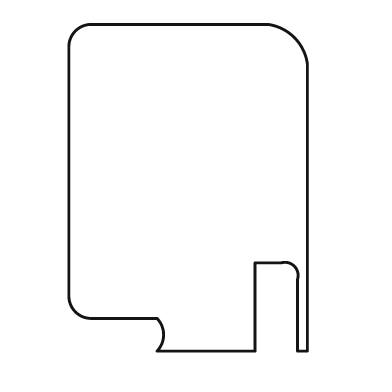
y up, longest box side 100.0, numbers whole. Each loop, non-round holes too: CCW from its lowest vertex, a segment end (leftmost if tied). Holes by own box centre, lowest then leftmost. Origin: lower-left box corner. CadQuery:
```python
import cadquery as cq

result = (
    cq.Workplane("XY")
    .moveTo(27.0, 0.0)
    .lineTo(57.0, 0.0)
    .lineTo(57.0, 27.0)
    .lineTo(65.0, 27.0)
    .threePointArc((69.0, 26.0), (70.0, 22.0))
    .lineTo(70.0, 0.0)
    .lineTo(73.0, 0.0)
    .lineTo(73.0, 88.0)
    .threePointArc((69.0, 96.0), (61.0, 100.0))
    .lineTo(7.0, 100.0)
    .threePointArc((2.0, 98.0), (0.0, 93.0))
    .lineTo(0.0, 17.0)
    .threePointArc((2.0, 12.0), (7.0, 10.0))
    .lineTo(27.0, 10.0)
    .threePointArc((29.0, 5.0), (27.0, 0.0))
    .close()
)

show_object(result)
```